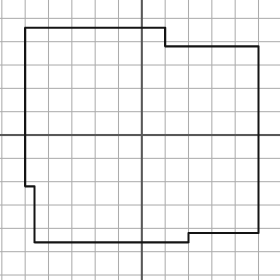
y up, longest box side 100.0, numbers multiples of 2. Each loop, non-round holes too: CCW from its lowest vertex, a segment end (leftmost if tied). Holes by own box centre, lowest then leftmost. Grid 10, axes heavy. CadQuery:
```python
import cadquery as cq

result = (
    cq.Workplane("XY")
    .moveTo(-46.0, -46.0)
    .lineTo(20.0, -46.0)
    .lineTo(20.0, -42.0)
    .lineTo(50.0, -42.0)
    .lineTo(50.0, 38.0)
    .lineTo(10.0, 38.0)
    .lineTo(10.0, 46.0)
    .lineTo(-50.0, 46.0)
    .lineTo(-50.0, -22.0)
    .lineTo(-46.0, -22.0)
    .close()
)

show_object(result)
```